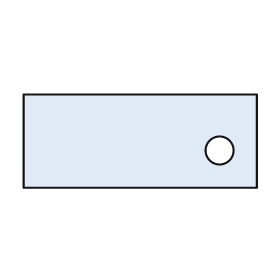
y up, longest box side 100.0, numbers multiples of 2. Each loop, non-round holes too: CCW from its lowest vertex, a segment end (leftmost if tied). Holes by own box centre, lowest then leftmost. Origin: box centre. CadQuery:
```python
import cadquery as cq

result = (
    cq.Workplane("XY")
    .moveTo(-50.0, -20.0)
    .lineTo(50.0, -20.0)
    .lineTo(50.0, 20.0)
    .lineTo(-50.0, 20.0)
    .close()
    .moveTo(34.0, -4.0)
    .circle(6.0)
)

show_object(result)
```